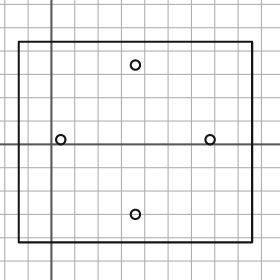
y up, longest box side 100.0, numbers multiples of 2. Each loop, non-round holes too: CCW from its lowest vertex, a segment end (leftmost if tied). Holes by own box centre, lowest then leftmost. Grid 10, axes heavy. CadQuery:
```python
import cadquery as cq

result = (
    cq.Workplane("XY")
    .moveTo(-14.0, -42.0)
    .lineTo(86.0, -42.0)
    .lineTo(86.0, 44.0)
    .lineTo(-14.0, 44.0)
    .close()
    .moveTo(36.0, -30.0)
    .circle(2.0)
    .moveTo(4.0, 2.0)
    .circle(2.0)
    .moveTo(68.0, 2.0)
    .circle(2.0)
    .moveTo(36.0, 34.0)
    .circle(2.0)
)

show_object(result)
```